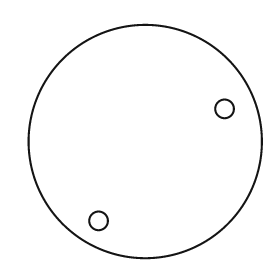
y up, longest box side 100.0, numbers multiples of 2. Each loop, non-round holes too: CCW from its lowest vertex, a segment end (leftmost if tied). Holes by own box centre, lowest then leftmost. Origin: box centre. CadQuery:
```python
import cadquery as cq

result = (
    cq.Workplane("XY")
    .moveTo(0.0, 0.0)
    .circle(50.0)
    .moveTo(-20.0, -34.0)
    .circle(4.0)
    .moveTo(34.0, 14.0)
    .circle(4.0)
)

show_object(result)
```